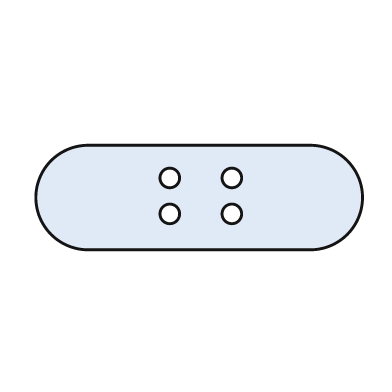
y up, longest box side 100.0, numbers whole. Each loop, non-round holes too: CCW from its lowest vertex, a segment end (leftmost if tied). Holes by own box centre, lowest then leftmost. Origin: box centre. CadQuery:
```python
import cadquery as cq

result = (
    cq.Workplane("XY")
    .moveTo(-34.0, -16.0)
    .lineTo(34.0, -16.0)
    .threePointArc((50.0, 0.0), (34.0, 16.0))
    .lineTo(-34.0, 16.0)
    .threePointArc((-50.0, 0.0), (-34.0, -16.0))
    .close()
    .moveTo(-9.0, -5.0)
    .circle(3.0)
    .moveTo(10.0, -5.0)
    .circle(3.0)
    .moveTo(-9.0, 6.0)
    .circle(3.0)
    .moveTo(10.0, 6.0)
    .circle(3.0)
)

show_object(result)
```